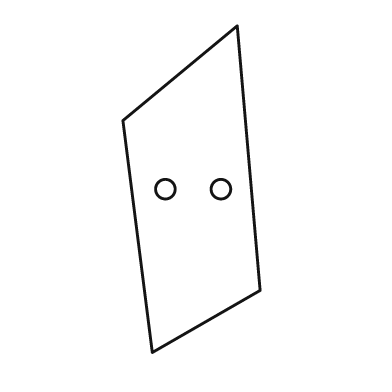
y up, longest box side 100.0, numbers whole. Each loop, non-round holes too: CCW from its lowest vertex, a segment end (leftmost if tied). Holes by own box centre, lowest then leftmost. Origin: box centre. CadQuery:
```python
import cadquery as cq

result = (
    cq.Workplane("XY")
    .moveTo(-12.0, -50.0)
    .lineTo(21.0, -31.0)
    .lineTo(14.0, 50.0)
    .lineTo(-21.0, 21.0)
    .close()
    .moveTo(-8.0, 0.0)
    .circle(3.0)
    .moveTo(9.0, 0.0)
    .circle(3.0)
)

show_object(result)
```